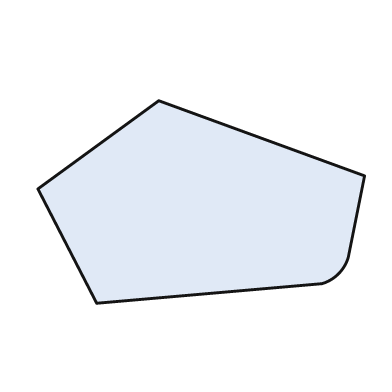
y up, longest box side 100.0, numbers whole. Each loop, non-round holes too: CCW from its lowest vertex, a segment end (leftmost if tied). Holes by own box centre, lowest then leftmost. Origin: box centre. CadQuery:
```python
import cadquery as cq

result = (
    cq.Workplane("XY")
    .moveTo(-32.0, -31.0)
    .lineTo(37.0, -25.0)
    .threePointArc((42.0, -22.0), (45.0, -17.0))
    .lineTo(50.0, 8.0)
    .lineTo(-13.0, 31.0)
    .lineTo(-50.0, 4.0)
    .close()
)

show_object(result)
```